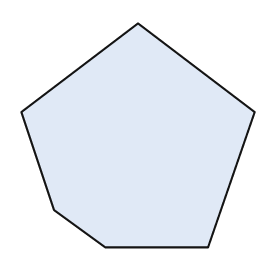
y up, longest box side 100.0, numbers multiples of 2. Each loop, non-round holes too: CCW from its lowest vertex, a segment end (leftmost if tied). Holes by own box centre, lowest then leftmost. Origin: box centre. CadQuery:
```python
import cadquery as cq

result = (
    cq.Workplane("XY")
    .moveTo(-14.0, -48.0)
    .lineTo(30.0, -48.0)
    .lineTo(50.0, 10.0)
    .lineTo(0.0, 48.0)
    .lineTo(-50.0, 10.0)
    .lineTo(-36.0, -32.0)
    .close()
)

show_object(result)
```